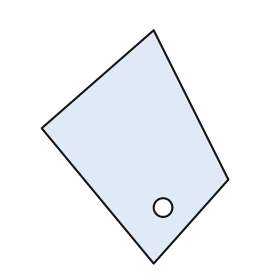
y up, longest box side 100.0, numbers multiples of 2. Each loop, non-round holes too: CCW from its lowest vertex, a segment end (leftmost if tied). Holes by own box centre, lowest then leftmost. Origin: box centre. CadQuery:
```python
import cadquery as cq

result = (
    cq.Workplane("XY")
    .moveTo(8.0, -50.0)
    .lineTo(40.0, -14.0)
    .lineTo(8.0, 50.0)
    .lineTo(-40.0, 8.0)
    .close()
    .moveTo(12.0, -26.0)
    .circle(4.0)
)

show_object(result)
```